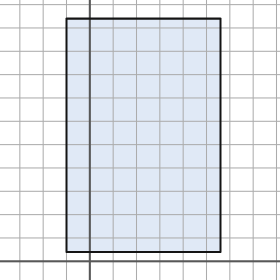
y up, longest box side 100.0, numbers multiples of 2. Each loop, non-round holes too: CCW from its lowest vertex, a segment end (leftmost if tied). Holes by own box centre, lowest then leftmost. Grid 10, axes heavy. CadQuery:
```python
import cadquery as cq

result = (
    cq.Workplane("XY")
    .moveTo(-10.0, 4.0)
    .lineTo(56.0, 4.0)
    .lineTo(56.0, 104.0)
    .lineTo(-10.0, 104.0)
    .close()
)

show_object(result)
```